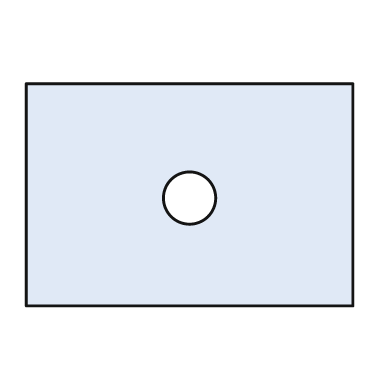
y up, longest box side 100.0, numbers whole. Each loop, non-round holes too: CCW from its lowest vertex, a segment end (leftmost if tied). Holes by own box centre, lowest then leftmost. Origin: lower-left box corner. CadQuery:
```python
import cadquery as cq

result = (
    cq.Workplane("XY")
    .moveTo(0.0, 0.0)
    .lineTo(100.0, 0.0)
    .lineTo(100.0, 68.0)
    .lineTo(0.0, 68.0)
    .close()
    .moveTo(50.0, 33.0)
    .circle(8.0)
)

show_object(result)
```